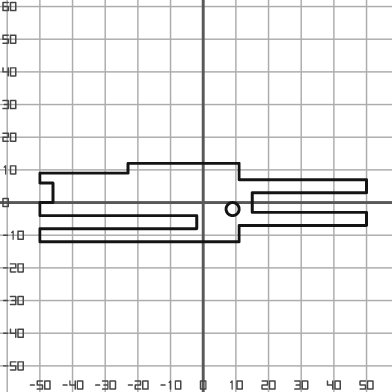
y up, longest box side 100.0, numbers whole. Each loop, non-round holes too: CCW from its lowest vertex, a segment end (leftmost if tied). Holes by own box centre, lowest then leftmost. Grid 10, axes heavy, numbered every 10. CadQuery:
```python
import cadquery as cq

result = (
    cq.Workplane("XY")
    .moveTo(-50.0, -12.0)
    .lineTo(11.0, -12.0)
    .lineTo(11.0, -7.0)
    .lineTo(50.0, -7.0)
    .lineTo(50.0, -3.0)
    .lineTo(15.0, -3.0)
    .lineTo(15.0, 3.0)
    .lineTo(50.0, 3.0)
    .lineTo(50.0, 7.0)
    .lineTo(11.0, 7.0)
    .lineTo(11.0, 12.0)
    .lineTo(-23.0, 12.0)
    .lineTo(-23.0, 9.0)
    .lineTo(-50.0, 9.0)
    .lineTo(-50.0, 6.0)
    .lineTo(-46.0, 6.0)
    .lineTo(-46.0, 0.0)
    .lineTo(-50.0, 0.0)
    .lineTo(-50.0, -4.0)
    .lineTo(-2.0, -4.0)
    .lineTo(-2.0, -8.0)
    .lineTo(-50.0, -8.0)
    .close()
    .moveTo(9.0, -2.0)
    .circle(2.0)
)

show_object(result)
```